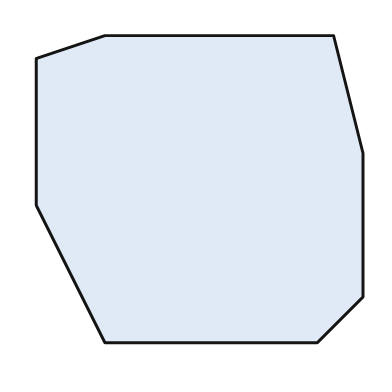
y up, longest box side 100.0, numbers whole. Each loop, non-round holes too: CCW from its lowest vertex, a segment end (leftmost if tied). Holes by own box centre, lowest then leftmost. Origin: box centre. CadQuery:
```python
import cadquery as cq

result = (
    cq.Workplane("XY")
    .moveTo(-29.0, -47.0)
    .lineTo(36.0, -47.0)
    .lineTo(50.0, -33.0)
    .lineTo(50.0, 11.0)
    .lineTo(41.0, 47.0)
    .lineTo(-29.0, 47.0)
    .lineTo(-50.0, 40.0)
    .lineTo(-50.0, -5.0)
    .close()
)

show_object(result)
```